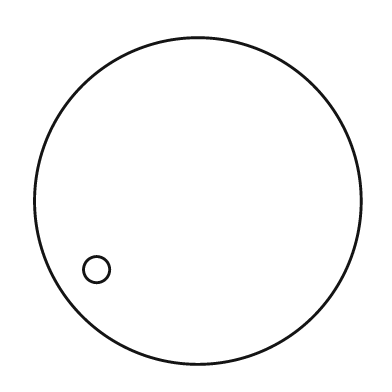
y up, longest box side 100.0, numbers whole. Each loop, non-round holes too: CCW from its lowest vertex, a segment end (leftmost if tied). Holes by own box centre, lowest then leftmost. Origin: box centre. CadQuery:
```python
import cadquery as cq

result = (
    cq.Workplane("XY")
    .moveTo(0.0, 0.0)
    .circle(50.0)
    .moveTo(-31.0, -21.0)
    .circle(4.0)
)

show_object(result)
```